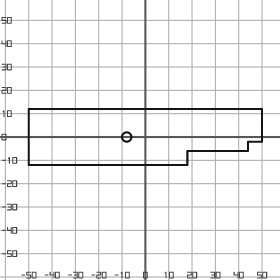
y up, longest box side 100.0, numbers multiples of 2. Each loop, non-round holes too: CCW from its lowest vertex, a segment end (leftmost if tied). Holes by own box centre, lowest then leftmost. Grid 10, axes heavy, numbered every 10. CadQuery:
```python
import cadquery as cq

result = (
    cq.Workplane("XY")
    .moveTo(-50.0, -12.0)
    .lineTo(18.0, -12.0)
    .lineTo(18.0, -6.0)
    .lineTo(44.0, -6.0)
    .lineTo(44.0, -2.0)
    .lineTo(50.0, -2.0)
    .lineTo(50.0, 12.0)
    .lineTo(-50.0, 12.0)
    .close()
    .moveTo(-8.0, 0.0)
    .circle(2.0)
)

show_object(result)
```